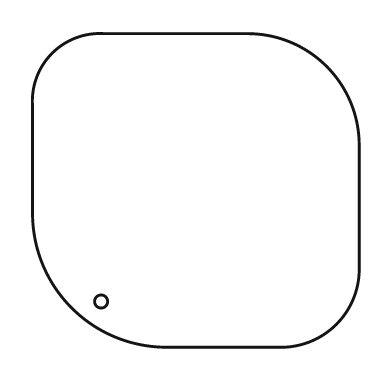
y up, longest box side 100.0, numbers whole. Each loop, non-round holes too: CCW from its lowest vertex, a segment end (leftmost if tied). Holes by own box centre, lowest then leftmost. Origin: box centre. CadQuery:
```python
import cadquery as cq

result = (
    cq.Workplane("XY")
    .moveTo(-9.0, -48.0)
    .lineTo(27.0, -48.0)
    .threePointArc((43.0, -41.0), (50.0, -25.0))
    .lineTo(50.0, 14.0)
    .threePointArc((40.0, 38.0), (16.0, 48.0))
    .lineTo(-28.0, 48.0)
    .threePointArc((-44.0, 42.0), (-50.0, 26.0))
    .lineTo(-50.0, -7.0)
    .threePointArc((-38.0, -36.0), (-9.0, -48.0))
    .close()
    .moveTo(-29.0, -34.0)
    .circle(2.0)
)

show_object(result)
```